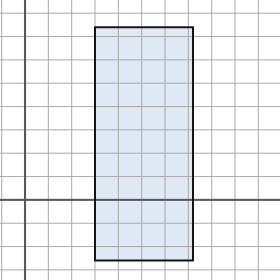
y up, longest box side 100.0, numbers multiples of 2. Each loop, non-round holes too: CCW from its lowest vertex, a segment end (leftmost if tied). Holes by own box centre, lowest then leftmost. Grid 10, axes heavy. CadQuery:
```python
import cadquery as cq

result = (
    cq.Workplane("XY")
    .moveTo(30.0, -26.0)
    .lineTo(72.0, -26.0)
    .lineTo(72.0, 74.0)
    .lineTo(30.0, 74.0)
    .close()
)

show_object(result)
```